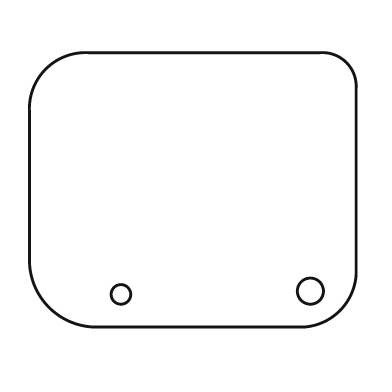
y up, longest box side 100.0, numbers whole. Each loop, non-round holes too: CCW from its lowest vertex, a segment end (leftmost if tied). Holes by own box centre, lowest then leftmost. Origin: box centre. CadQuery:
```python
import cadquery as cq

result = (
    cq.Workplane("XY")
    .moveTo(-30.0, -42.0)
    .lineTo(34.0, -42.0)
    .threePointArc((45.0, -37.0), (50.0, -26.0))
    .lineTo(50.0, 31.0)
    .threePointArc((47.0, 39.0), (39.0, 42.0))
    .lineTo(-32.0, 42.0)
    .threePointArc((-45.0, 37.0), (-50.0, 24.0))
    .lineTo(-50.0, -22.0)
    .threePointArc((-44.0, -36.0), (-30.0, -42.0))
    .close()
    .moveTo(-22.0, -32.0)
    .circle(3.0)
    .moveTo(36.0, -31.0)
    .circle(4.0)
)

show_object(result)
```